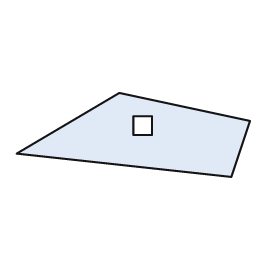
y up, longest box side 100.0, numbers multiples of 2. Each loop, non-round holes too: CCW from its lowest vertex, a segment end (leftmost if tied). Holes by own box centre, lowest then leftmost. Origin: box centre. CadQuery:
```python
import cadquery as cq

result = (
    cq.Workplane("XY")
    .moveTo(42.0, -18.0)
    .lineTo(50.0, 6.0)
    .lineTo(-6.0, 18.0)
    .lineTo(-50.0, -8.0)
    .close()
    .moveTo(0.0, 0.0)
    .lineTo(8.0, 0.0)
    .lineTo(8.0, 8.0)
    .lineTo(0.0, 8.0)
    .close()
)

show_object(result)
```